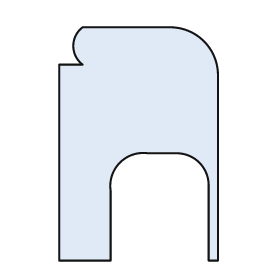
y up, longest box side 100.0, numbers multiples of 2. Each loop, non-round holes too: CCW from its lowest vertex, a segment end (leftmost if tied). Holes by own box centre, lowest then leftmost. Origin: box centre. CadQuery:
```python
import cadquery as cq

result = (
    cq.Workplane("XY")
    .moveTo(-34.0, -50.0)
    .lineTo(-12.0, -50.0)
    .lineTo(-12.0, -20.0)
    .threePointArc((-8.0, -8.0), (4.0, -4.0))
    .lineTo(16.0, -4.0)
    .threePointArc((26.0, -8.0), (30.0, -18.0))
    .lineTo(30.0, -50.0)
    .lineTo(34.0, -50.0)
    .lineTo(34.0, 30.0)
    .threePointArc((28.0, 44.0), (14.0, 50.0))
    .lineTo(-24.0, 50.0)
    .threePointArc((-28.0, 42.0), (-24.0, 34.0))
    .lineTo(-34.0, 34.0)
    .close()
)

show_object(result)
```